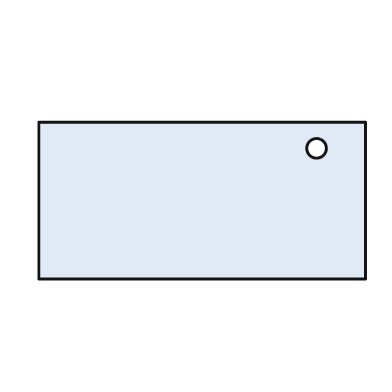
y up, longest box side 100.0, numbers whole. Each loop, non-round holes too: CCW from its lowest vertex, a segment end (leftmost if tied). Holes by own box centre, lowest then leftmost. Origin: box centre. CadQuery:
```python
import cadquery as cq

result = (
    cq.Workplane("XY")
    .moveTo(-50.0, -24.0)
    .lineTo(50.0, -24.0)
    .lineTo(50.0, 24.0)
    .lineTo(-50.0, 24.0)
    .close()
    .moveTo(35.0, 16.0)
    .circle(3.0)
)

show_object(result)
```